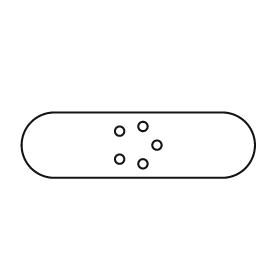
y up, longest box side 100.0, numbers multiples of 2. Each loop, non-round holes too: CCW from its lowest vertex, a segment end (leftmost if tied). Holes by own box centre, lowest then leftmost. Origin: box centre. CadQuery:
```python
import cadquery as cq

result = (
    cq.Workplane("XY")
    .moveTo(-36.0, -14.0)
    .lineTo(36.0, -14.0)
    .threePointArc((50.0, 0.0), (36.0, 14.0))
    .lineTo(-36.0, 14.0)
    .threePointArc((-50.0, 0.0), (-36.0, -14.0))
    .close()
    .moveTo(2.0, -8.0)
    .circle(2.0)
    .moveTo(-8.0, -6.0)
    .circle(2.0)
    .moveTo(8.0, 0.0)
    .circle(2.0)
    .moveTo(-8.0, 6.0)
    .circle(2.0)
    .moveTo(2.0, 8.0)
    .circle(2.0)
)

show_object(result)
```